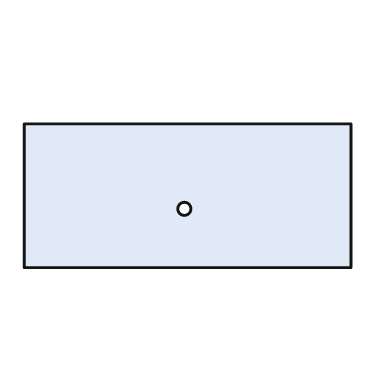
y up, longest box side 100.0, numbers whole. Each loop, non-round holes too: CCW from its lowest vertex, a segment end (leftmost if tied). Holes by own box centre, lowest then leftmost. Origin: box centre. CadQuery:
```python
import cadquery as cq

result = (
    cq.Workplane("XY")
    .moveTo(-50.0, -22.0)
    .lineTo(50.0, -22.0)
    .lineTo(50.0, 22.0)
    .lineTo(-50.0, 22.0)
    .close()
    .moveTo(-1.0, -4.0)
    .circle(2.0)
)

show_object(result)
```